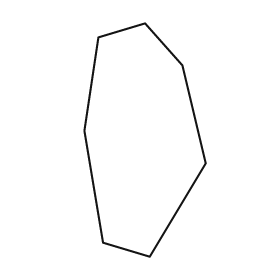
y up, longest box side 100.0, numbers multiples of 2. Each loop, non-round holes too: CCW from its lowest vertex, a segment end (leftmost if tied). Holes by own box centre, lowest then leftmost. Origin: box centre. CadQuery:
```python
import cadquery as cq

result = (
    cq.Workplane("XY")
    .moveTo(2.0, -50.0)
    .lineTo(26.0, -10.0)
    .lineTo(16.0, 32.0)
    .lineTo(0.0, 50.0)
    .lineTo(-20.0, 44.0)
    .lineTo(-26.0, 4.0)
    .lineTo(-18.0, -44.0)
    .close()
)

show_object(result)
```